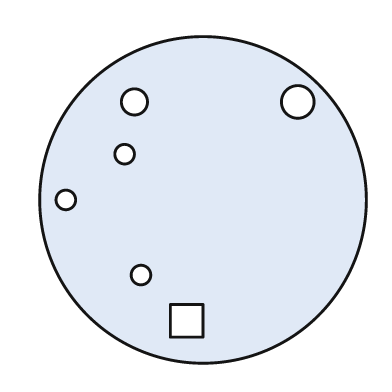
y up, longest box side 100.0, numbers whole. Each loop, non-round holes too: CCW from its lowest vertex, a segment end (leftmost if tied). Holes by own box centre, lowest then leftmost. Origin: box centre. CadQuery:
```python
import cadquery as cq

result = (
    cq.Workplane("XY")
    .moveTo(0.0, 0.0)
    .circle(50.0)
    .moveTo(-10.0, -42.0)
    .lineTo(0.0, -42.0)
    .lineTo(0.0, -32.0)
    .lineTo(-10.0, -32.0)
    .close()
    .moveTo(-19.0, -23.0)
    .circle(3.0)
    .moveTo(-42.0, 0.0)
    .circle(3.0)
    .moveTo(-24.0, 14.0)
    .circle(3.0)
    .moveTo(-21.0, 30.0)
    .circle(4.0)
    .moveTo(29.0, 30.0)
    .circle(5.0)
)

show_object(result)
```